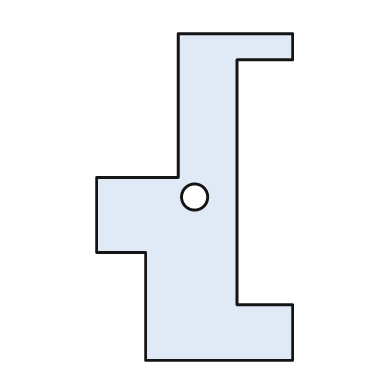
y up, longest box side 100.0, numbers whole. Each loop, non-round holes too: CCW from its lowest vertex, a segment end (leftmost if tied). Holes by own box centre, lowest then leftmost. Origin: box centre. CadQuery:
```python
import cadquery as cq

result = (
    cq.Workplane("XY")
    .moveTo(-15.0, -50.0)
    .lineTo(30.0, -50.0)
    .lineTo(30.0, -33.0)
    .lineTo(13.0, -33.0)
    .lineTo(13.0, 42.0)
    .lineTo(30.0, 42.0)
    .lineTo(30.0, 50.0)
    .lineTo(-5.0, 50.0)
    .lineTo(-5.0, 6.0)
    .lineTo(-30.0, 6.0)
    .lineTo(-30.0, -17.0)
    .lineTo(-15.0, -17.0)
    .close()
    .moveTo(0.0, 0.0)
    .circle(4.0)
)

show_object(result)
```